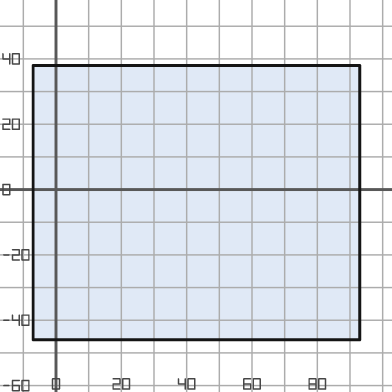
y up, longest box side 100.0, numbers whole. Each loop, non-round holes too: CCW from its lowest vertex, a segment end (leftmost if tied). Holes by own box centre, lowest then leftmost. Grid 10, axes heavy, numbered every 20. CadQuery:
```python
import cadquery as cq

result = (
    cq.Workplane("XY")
    .moveTo(-7.0, -46.0)
    .lineTo(93.0, -46.0)
    .lineTo(93.0, 38.0)
    .lineTo(-7.0, 38.0)
    .close()
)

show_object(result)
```